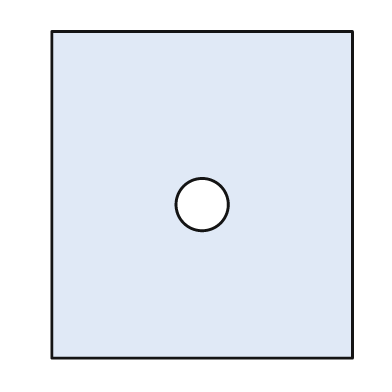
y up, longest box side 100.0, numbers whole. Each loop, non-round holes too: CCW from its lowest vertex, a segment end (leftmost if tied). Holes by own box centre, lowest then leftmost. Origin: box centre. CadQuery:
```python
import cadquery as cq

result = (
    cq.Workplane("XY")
    .moveTo(-46.0, -50.0)
    .lineTo(46.0, -50.0)
    .lineTo(46.0, 50.0)
    .lineTo(-46.0, 50.0)
    .close()
    .moveTo(0.0, -3.0)
    .circle(8.0)
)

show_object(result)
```